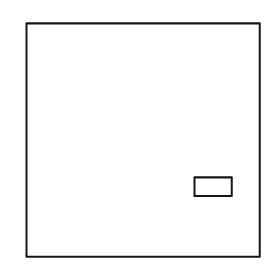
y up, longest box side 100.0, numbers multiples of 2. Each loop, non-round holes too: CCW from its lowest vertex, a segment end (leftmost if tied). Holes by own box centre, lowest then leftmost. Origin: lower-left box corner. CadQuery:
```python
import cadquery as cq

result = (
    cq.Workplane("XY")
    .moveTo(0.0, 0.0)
    .lineTo(100.0, 0.0)
    .lineTo(100.0, 100.0)
    .lineTo(0.0, 100.0)
    .close()
    .moveTo(72.0, 26.0)
    .lineTo(88.0, 26.0)
    .lineTo(88.0, 34.0)
    .lineTo(72.0, 34.0)
    .close()
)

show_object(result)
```